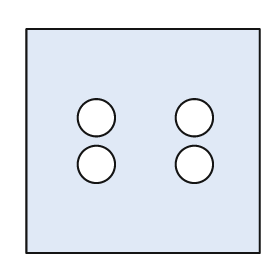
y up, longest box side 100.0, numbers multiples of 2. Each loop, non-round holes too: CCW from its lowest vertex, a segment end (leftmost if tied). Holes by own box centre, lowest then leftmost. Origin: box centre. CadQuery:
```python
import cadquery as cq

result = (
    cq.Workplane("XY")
    .moveTo(-50.0, -48.0)
    .lineTo(50.0, -48.0)
    .lineTo(50.0, 48.0)
    .lineTo(-50.0, 48.0)
    .close()
    .moveTo(-20.0, -10.0)
    .circle(8.0)
    .moveTo(22.0, -10.0)
    .circle(8.0)
    .moveTo(-20.0, 10.0)
    .circle(8.0)
    .moveTo(22.0, 10.0)
    .circle(8.0)
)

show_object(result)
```